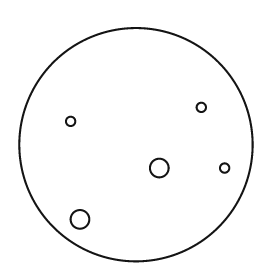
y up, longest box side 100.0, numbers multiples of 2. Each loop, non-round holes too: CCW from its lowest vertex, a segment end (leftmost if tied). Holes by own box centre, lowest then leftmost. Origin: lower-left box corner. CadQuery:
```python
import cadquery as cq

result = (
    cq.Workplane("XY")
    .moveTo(50.0, 50.0)
    .circle(50.0)
    .moveTo(26.0, 18.0)
    .circle(4.0)
    .moveTo(60.0, 40.0)
    .circle(4.0)
    .moveTo(88.0, 40.0)
    .circle(2.0)
    .moveTo(22.0, 60.0)
    .circle(2.0)
    .moveTo(78.0, 66.0)
    .circle(2.0)
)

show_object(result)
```